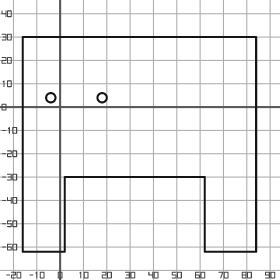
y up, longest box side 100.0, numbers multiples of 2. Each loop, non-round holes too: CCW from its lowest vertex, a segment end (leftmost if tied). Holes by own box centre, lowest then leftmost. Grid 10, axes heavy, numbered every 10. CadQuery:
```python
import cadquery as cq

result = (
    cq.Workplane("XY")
    .moveTo(-16.0, -62.0)
    .lineTo(2.0, -62.0)
    .lineTo(2.0, -30.0)
    .lineTo(62.0, -30.0)
    .lineTo(62.0, -62.0)
    .lineTo(84.0, -62.0)
    .lineTo(84.0, 30.0)
    .lineTo(-16.0, 30.0)
    .close()
    .moveTo(-4.0, 4.0)
    .circle(2.0)
    .moveTo(18.0, 4.0)
    .circle(2.0)
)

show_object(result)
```